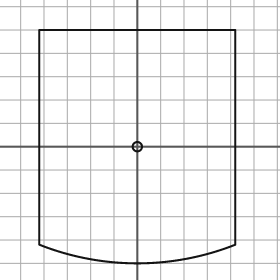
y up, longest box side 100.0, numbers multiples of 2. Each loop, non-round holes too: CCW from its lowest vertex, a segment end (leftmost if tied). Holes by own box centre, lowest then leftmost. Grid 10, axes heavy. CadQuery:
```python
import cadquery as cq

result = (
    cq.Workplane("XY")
    .moveTo(-42.0, -42.0)
    .threePointArc((0.0, -50.0), (42.0, -42.0))
    .lineTo(42.0, 50.0)
    .lineTo(-42.0, 50.0)
    .close()
    .moveTo(0.0, 0.0)
    .circle(2.0)
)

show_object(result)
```